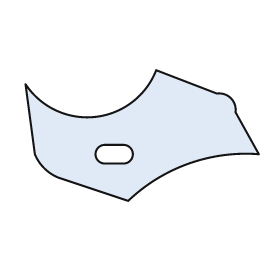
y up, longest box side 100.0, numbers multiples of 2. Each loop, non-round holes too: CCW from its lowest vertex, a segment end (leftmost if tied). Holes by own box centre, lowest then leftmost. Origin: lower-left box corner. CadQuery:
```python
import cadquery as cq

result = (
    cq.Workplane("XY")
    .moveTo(44.0, 0.0)
    .threePointArc((70.0, 16.0), (100.0, 20.0))
    .lineTo(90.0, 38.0)
    .threePointArc((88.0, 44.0), (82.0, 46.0))
    .lineTo(56.0, 56.0)
    .threePointArc((30.0, 36.0), (0.0, 50.0))
    .lineTo(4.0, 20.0)
    .threePointArc((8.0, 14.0), (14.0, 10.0))
    .close()
    .moveTo(34.0, 16.0)
    .lineTo(42.0, 16.0)
    .threePointArc((46.0, 20.0), (42.0, 24.0))
    .lineTo(34.0, 24.0)
    .threePointArc((30.0, 20.0), (34.0, 16.0))
    .close()
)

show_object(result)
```